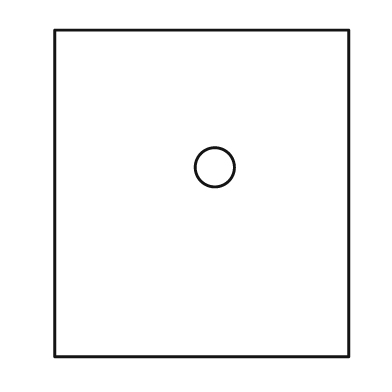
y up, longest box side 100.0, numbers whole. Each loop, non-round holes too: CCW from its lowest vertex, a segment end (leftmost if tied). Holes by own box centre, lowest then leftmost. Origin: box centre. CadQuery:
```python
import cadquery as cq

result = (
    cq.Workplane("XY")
    .moveTo(-45.0, -50.0)
    .lineTo(45.0, -50.0)
    .lineTo(45.0, 50.0)
    .lineTo(-45.0, 50.0)
    .close()
    .moveTo(4.0, 8.0)
    .circle(6.0)
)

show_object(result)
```